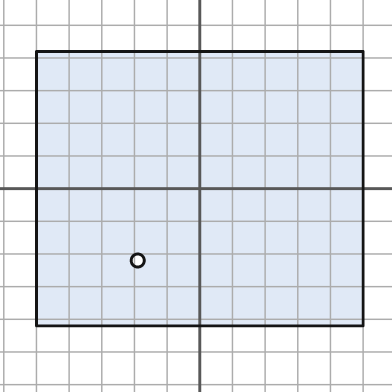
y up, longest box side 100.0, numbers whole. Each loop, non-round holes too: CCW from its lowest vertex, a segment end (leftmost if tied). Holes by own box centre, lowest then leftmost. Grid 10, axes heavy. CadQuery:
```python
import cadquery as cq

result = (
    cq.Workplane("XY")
    .moveTo(-50.0, -42.0)
    .lineTo(50.0, -42.0)
    .lineTo(50.0, 42.0)
    .lineTo(-50.0, 42.0)
    .close()
    .moveTo(-19.0, -22.0)
    .circle(2.0)
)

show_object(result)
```